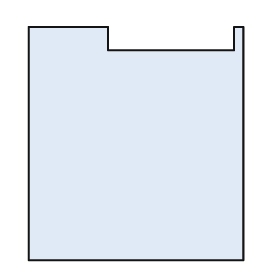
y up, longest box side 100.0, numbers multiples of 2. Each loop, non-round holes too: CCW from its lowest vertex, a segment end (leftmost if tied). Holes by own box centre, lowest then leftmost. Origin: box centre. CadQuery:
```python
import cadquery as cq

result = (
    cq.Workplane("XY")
    .moveTo(-46.0, -50.0)
    .lineTo(46.0, -50.0)
    .lineTo(46.0, 50.0)
    .lineTo(42.0, 50.0)
    .lineTo(42.0, 40.0)
    .lineTo(-12.0, 40.0)
    .lineTo(-12.0, 50.0)
    .lineTo(-46.0, 50.0)
    .close()
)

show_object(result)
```